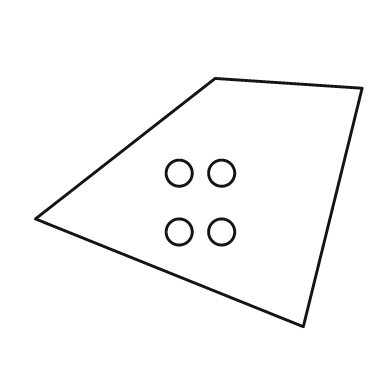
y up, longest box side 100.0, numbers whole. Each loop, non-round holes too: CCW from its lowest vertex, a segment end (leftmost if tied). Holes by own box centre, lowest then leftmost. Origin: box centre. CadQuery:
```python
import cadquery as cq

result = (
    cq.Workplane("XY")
    .moveTo(32.0, -38.0)
    .lineTo(50.0, 35.0)
    .lineTo(5.0, 38.0)
    .lineTo(-50.0, -5.0)
    .close()
    .moveTo(-6.0, -9.0)
    .circle(4.0)
    .moveTo(7.0, -9.0)
    .circle(4.0)
    .moveTo(-6.0, 9.0)
    .circle(4.0)
    .moveTo(7.0, 9.0)
    .circle(4.0)
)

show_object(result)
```